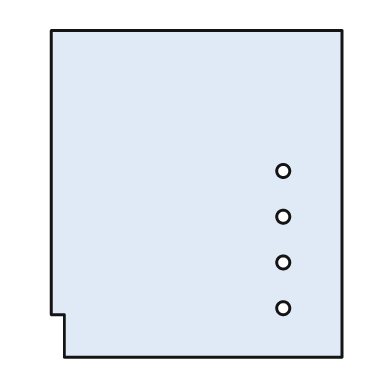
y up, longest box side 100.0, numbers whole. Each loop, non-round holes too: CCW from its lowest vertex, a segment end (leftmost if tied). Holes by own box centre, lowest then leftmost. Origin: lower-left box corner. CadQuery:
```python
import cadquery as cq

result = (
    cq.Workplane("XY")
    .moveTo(4.0, 0.0)
    .lineTo(89.0, 0.0)
    .lineTo(89.0, 100.0)
    .lineTo(0.0, 100.0)
    .lineTo(0.0, 13.0)
    .lineTo(4.0, 13.0)
    .close()
    .moveTo(71.0, 15.0)
    .circle(2.0)
    .moveTo(71.0, 29.0)
    .circle(2.0)
    .moveTo(71.0, 43.0)
    .circle(2.0)
    .moveTo(71.0, 57.0)
    .circle(2.0)
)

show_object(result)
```